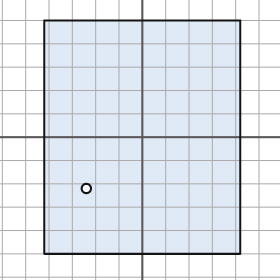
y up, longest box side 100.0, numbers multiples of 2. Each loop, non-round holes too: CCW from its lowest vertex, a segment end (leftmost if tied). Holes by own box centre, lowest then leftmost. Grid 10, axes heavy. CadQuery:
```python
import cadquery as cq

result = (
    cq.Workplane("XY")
    .moveTo(-42.0, -50.0)
    .lineTo(42.0, -50.0)
    .lineTo(42.0, 50.0)
    .lineTo(-42.0, 50.0)
    .close()
    .moveTo(-24.0, -22.0)
    .circle(2.0)
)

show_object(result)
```